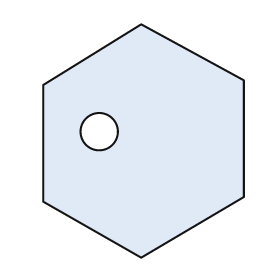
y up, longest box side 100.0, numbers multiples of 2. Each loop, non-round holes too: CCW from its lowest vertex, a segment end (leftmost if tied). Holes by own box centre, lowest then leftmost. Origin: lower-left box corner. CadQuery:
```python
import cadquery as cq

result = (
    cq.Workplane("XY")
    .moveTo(42.0, 0.0)
    .lineTo(86.0, 26.0)
    .lineTo(86.0, 76.0)
    .lineTo(42.0, 100.0)
    .lineTo(0.0, 74.0)
    .lineTo(0.0, 24.0)
    .close()
    .moveTo(24.0, 54.0)
    .circle(8.0)
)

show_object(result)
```